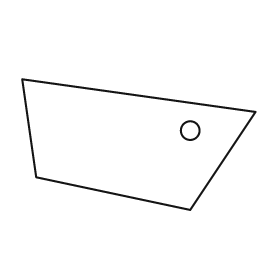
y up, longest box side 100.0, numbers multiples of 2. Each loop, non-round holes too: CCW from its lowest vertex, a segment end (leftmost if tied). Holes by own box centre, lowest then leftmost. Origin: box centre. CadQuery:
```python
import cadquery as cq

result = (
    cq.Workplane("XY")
    .moveTo(22.0, -28.0)
    .lineTo(50.0, 14.0)
    .lineTo(-50.0, 28.0)
    .lineTo(-44.0, -14.0)
    .close()
    .moveTo(22.0, 6.0)
    .circle(4.0)
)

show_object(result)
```